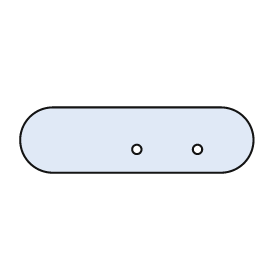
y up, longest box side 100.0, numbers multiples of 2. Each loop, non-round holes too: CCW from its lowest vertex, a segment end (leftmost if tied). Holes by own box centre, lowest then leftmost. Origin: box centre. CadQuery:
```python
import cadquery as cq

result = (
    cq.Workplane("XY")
    .moveTo(-36.0, -14.0)
    .lineTo(36.0, -14.0)
    .threePointArc((50.0, 0.0), (36.0, 14.0))
    .lineTo(-36.0, 14.0)
    .threePointArc((-50.0, 0.0), (-36.0, -14.0))
    .close()
    .moveTo(0.0, -4.0)
    .circle(2.0)
    .moveTo(26.0, -4.0)
    .circle(2.0)
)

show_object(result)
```